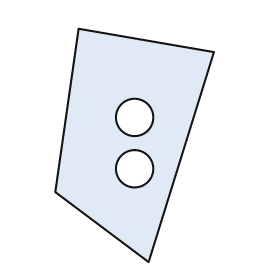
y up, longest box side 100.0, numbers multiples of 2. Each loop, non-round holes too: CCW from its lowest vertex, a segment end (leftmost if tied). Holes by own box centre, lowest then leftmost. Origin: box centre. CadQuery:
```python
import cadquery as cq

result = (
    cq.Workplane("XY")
    .moveTo(6.0, -50.0)
    .lineTo(34.0, 40.0)
    .lineTo(-24.0, 50.0)
    .lineTo(-34.0, -20.0)
    .close()
    .moveTo(0.0, -10.0)
    .circle(8.0)
    .moveTo(0.0, 12.0)
    .circle(8.0)
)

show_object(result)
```